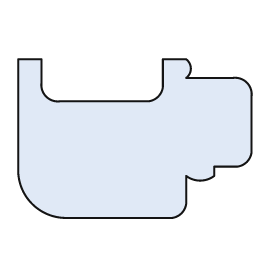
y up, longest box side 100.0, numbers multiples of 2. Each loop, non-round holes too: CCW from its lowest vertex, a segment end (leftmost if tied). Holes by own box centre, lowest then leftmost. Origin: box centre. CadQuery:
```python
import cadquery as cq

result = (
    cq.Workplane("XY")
    .moveTo(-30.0, -34.0)
    .lineTo(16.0, -34.0)
    .threePointArc((20.0, -32.0), (22.0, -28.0))
    .lineTo(22.0, -16.0)
    .threePointArc((28.0, -18.0), (34.0, -16.0))
    .lineTo(34.0, -12.0)
    .lineTo(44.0, -12.0)
    .threePointArc((48.0, -10.0), (50.0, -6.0))
    .lineTo(50.0, 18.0)
    .threePointArc((48.0, 24.0), (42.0, 26.0))
    .lineTo(22.0, 26.0)
    .threePointArc((24.0, 30.0), (22.0, 34.0))
    .lineTo(12.0, 34.0)
    .lineTo(12.0, 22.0)
    .threePointArc((10.0, 18.0), (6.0, 16.0))
    .lineTo(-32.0, 16.0)
    .threePointArc((-38.0, 18.0), (-40.0, 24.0))
    .lineTo(-40.0, 34.0)
    .lineTo(-50.0, 34.0)
    .lineTo(-50.0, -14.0)
    .threePointArc((-44.0, -28.0), (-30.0, -34.0))
    .close()
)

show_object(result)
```